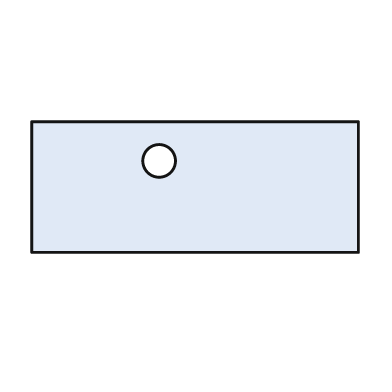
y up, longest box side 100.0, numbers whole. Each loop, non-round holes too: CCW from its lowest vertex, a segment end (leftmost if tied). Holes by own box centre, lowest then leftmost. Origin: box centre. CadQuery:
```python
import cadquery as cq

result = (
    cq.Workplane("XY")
    .moveTo(-50.0, -20.0)
    .lineTo(50.0, -20.0)
    .lineTo(50.0, 20.0)
    .lineTo(-50.0, 20.0)
    .close()
    .moveTo(-11.0, 8.0)
    .circle(5.0)
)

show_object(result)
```